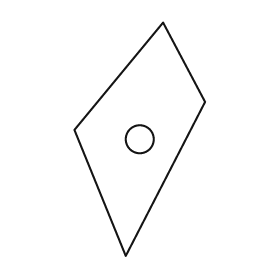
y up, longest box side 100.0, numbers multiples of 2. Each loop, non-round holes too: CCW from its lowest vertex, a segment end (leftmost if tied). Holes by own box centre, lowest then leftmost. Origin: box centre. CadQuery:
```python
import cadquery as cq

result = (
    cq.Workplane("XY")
    .moveTo(-6.0, -50.0)
    .lineTo(28.0, 16.0)
    .lineTo(10.0, 50.0)
    .lineTo(-28.0, 4.0)
    .close()
    .moveTo(0.0, 0.0)
    .circle(6.0)
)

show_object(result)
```